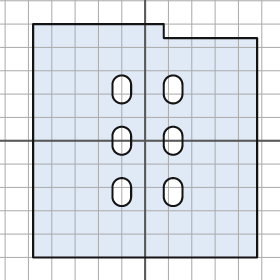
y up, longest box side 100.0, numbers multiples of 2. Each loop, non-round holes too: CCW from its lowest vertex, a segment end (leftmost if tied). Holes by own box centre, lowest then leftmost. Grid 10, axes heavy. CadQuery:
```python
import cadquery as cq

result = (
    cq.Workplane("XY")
    .moveTo(-48.0, -50.0)
    .lineTo(48.0, -50.0)
    .lineTo(48.0, 44.0)
    .lineTo(8.0, 44.0)
    .lineTo(8.0, 50.0)
    .lineTo(-48.0, 50.0)
    .close()
    .moveTo(-14.0, -24.0)
    .threePointArc((-10.0, -28.0), (-6.0, -24.0))
    .lineTo(-6.0, -20.0)
    .threePointArc((-10.0, -16.0), (-14.0, -20.0))
    .close()
    .moveTo(8.0, -24.0)
    .threePointArc((12.0, -28.0), (16.0, -24.0))
    .lineTo(16.0, -20.0)
    .threePointArc((12.0, -16.0), (8.0, -20.0))
    .close()
    .moveTo(-14.0, -2.0)
    .threePointArc((-10.0, -6.0), (-6.0, -2.0))
    .lineTo(-6.0, 2.0)
    .threePointArc((-10.0, 6.0), (-14.0, 2.0))
    .close()
    .moveTo(8.0, -2.0)
    .threePointArc((12.0, -6.0), (16.0, -2.0))
    .lineTo(16.0, 2.0)
    .threePointArc((12.0, 6.0), (8.0, 2.0))
    .close()
    .moveTo(-14.0, 20.0)
    .threePointArc((-10.0, 16.0), (-6.0, 20.0))
    .lineTo(-6.0, 24.0)
    .threePointArc((-10.0, 28.0), (-14.0, 24.0))
    .close()
    .moveTo(8.0, 20.0)
    .threePointArc((12.0, 16.0), (16.0, 20.0))
    .lineTo(16.0, 24.0)
    .threePointArc((12.0, 28.0), (8.0, 24.0))
    .close()
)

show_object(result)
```